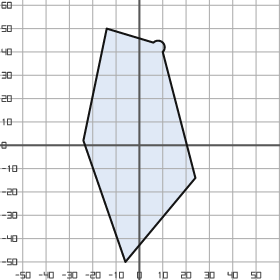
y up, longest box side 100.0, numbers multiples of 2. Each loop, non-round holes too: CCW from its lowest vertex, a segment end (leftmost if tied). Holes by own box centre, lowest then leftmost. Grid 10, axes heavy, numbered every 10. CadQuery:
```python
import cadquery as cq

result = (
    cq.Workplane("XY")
    .moveTo(-6.0, -50.0)
    .lineTo(24.0, -14.0)
    .lineTo(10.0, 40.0)
    .threePointArc((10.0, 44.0), (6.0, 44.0))
    .lineTo(-14.0, 50.0)
    .lineTo(-24.0, 2.0)
    .close()
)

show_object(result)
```